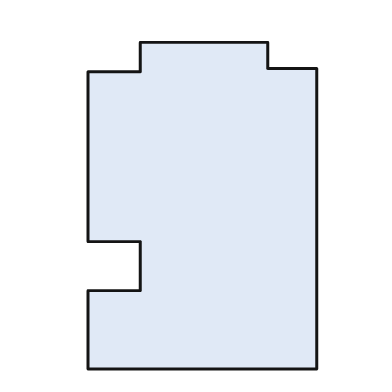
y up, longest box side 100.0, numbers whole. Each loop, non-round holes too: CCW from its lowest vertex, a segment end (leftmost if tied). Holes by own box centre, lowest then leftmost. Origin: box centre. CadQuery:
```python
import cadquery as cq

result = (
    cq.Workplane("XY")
    .moveTo(-35.0, -50.0)
    .lineTo(35.0, -50.0)
    .lineTo(35.0, 42.0)
    .lineTo(20.0, 42.0)
    .lineTo(20.0, 50.0)
    .lineTo(-19.0, 50.0)
    .lineTo(-19.0, 41.0)
    .lineTo(-35.0, 41.0)
    .lineTo(-35.0, -11.0)
    .lineTo(-19.0, -11.0)
    .lineTo(-19.0, -26.0)
    .lineTo(-35.0, -26.0)
    .close()
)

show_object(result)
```